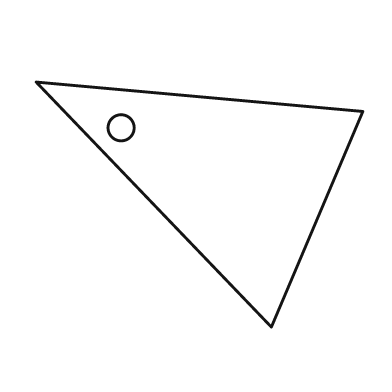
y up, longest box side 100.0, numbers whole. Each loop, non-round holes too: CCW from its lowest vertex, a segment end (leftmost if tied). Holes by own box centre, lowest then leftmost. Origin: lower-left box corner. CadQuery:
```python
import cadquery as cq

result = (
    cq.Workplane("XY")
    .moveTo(72.0, 0.0)
    .lineTo(100.0, 66.0)
    .lineTo(0.0, 75.0)
    .close()
    .moveTo(26.0, 61.0)
    .circle(4.0)
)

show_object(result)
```